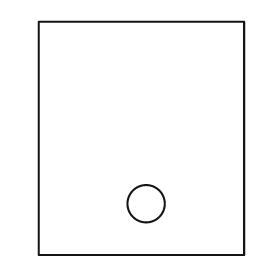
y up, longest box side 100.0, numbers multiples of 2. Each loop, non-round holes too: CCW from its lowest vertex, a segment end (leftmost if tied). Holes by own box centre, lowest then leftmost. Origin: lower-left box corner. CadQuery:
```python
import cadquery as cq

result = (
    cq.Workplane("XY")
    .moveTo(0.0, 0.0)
    .lineTo(88.0, 0.0)
    .lineTo(88.0, 100.0)
    .lineTo(0.0, 100.0)
    .close()
    .moveTo(46.0, 22.0)
    .circle(8.0)
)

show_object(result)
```